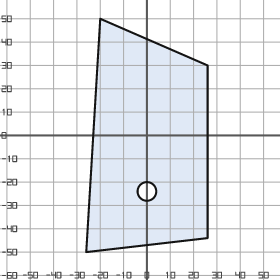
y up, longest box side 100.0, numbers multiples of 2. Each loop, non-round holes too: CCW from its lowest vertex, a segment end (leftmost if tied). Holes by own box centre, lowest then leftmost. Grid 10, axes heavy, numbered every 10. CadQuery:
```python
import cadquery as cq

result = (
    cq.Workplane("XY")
    .moveTo(-26.0, -50.0)
    .lineTo(26.0, -44.0)
    .lineTo(26.0, 30.0)
    .lineTo(-20.0, 50.0)
    .close()
    .moveTo(0.0, -24.0)
    .circle(4.0)
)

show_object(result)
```